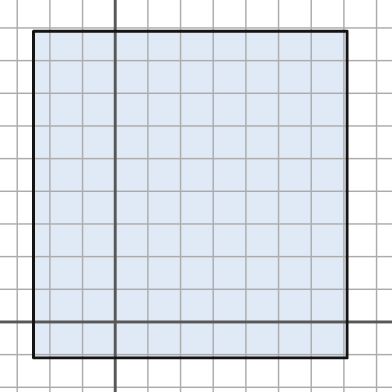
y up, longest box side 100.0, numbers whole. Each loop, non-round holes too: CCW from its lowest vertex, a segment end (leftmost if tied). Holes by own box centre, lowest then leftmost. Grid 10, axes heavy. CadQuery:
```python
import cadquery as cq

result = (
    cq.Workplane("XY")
    .moveTo(-25.0, -11.0)
    .lineTo(71.0, -11.0)
    .lineTo(71.0, 89.0)
    .lineTo(-25.0, 89.0)
    .close()
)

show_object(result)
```